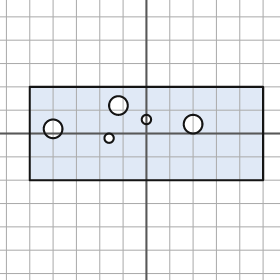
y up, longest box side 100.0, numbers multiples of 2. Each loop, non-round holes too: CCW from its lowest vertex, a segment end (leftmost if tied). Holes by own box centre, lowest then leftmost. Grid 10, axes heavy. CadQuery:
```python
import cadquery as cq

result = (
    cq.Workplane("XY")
    .moveTo(-50.0, -20.0)
    .lineTo(50.0, -20.0)
    .lineTo(50.0, 20.0)
    .lineTo(-50.0, 20.0)
    .close()
    .moveTo(-16.0, -2.0)
    .circle(2.0)
    .moveTo(-40.0, 2.0)
    .circle(4.0)
    .moveTo(20.0, 4.0)
    .circle(4.0)
    .moveTo(0.0, 6.0)
    .circle(2.0)
    .moveTo(-12.0, 12.0)
    .circle(4.0)
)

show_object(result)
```